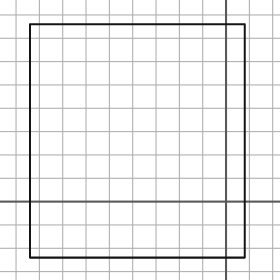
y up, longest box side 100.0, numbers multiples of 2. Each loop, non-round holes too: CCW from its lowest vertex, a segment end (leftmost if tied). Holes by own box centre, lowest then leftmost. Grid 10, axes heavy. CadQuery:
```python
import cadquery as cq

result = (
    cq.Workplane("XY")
    .moveTo(-84.0, -24.0)
    .lineTo(8.0, -24.0)
    .lineTo(8.0, 76.0)
    .lineTo(-84.0, 76.0)
    .close()
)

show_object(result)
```